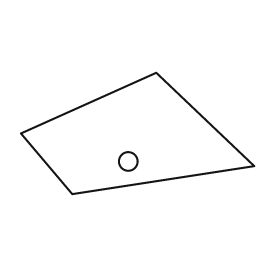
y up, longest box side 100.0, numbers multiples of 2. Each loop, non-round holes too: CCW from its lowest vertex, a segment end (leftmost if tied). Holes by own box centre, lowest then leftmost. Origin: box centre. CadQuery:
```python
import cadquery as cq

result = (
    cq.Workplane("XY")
    .moveTo(-28.0, -26.0)
    .lineTo(50.0, -14.0)
    .lineTo(8.0, 26.0)
    .lineTo(-50.0, 0.0)
    .close()
    .moveTo(-4.0, -12.0)
    .circle(4.0)
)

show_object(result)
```